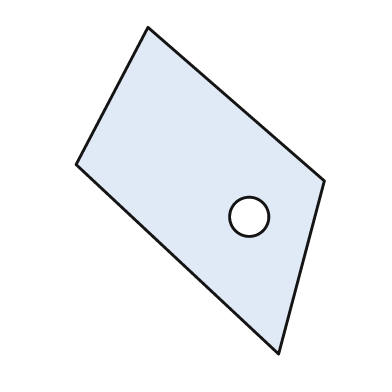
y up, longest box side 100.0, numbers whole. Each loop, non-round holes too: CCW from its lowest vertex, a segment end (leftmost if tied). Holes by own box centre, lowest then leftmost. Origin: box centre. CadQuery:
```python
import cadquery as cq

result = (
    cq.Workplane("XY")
    .moveTo(24.0, -50.0)
    .lineTo(38.0, 3.0)
    .lineTo(-16.0, 50.0)
    .lineTo(-38.0, 8.0)
    .close()
    .moveTo(15.0, -8.0)
    .circle(6.0)
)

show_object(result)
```